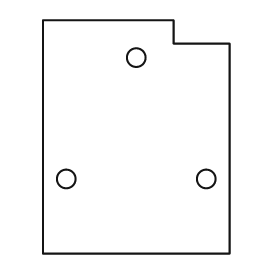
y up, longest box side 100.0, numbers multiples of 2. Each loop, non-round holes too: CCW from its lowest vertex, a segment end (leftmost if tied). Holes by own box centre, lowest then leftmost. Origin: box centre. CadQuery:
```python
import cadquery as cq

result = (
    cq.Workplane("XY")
    .moveTo(-40.0, -50.0)
    .lineTo(40.0, -50.0)
    .lineTo(40.0, 40.0)
    .lineTo(16.0, 40.0)
    .lineTo(16.0, 50.0)
    .lineTo(-40.0, 50.0)
    .close()
    .moveTo(-30.0, -18.0)
    .circle(4.0)
    .moveTo(30.0, -18.0)
    .circle(4.0)
    .moveTo(0.0, 34.0)
    .circle(4.0)
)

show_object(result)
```